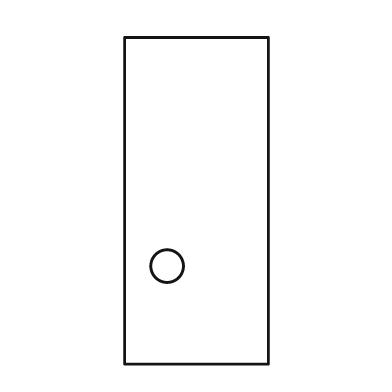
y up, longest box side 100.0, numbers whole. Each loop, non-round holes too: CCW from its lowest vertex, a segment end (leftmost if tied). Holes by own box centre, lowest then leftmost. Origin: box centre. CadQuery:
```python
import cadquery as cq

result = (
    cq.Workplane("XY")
    .moveTo(-22.0, -50.0)
    .lineTo(22.0, -50.0)
    .lineTo(22.0, 50.0)
    .lineTo(-22.0, 50.0)
    .close()
    .moveTo(-9.0, -20.0)
    .circle(5.0)
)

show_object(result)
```